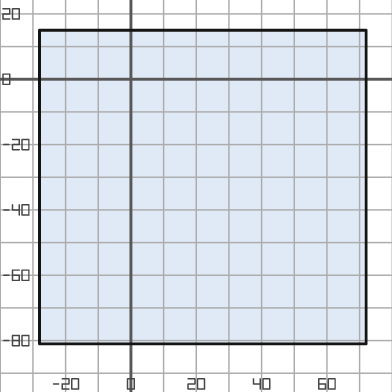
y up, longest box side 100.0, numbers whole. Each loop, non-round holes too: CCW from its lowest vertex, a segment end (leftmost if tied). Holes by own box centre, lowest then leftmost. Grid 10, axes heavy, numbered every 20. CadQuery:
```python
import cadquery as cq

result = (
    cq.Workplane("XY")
    .moveTo(-28.0, -81.0)
    .lineTo(72.0, -81.0)
    .lineTo(72.0, 15.0)
    .lineTo(-28.0, 15.0)
    .close()
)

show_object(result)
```